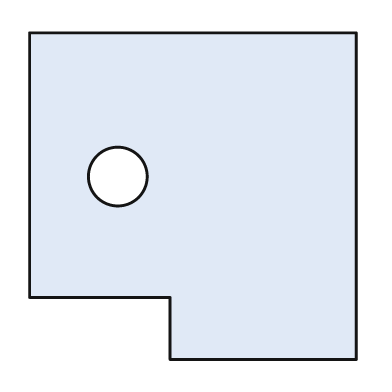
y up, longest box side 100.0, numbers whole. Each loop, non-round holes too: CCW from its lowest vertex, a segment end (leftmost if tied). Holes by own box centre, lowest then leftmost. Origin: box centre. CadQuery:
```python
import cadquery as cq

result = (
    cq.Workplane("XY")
    .moveTo(-7.0, -50.0)
    .lineTo(50.0, -50.0)
    .lineTo(50.0, 50.0)
    .lineTo(-50.0, 50.0)
    .lineTo(-50.0, -31.0)
    .lineTo(-7.0, -31.0)
    .close()
    .moveTo(-23.0, 6.0)
    .circle(9.0)
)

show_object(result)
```